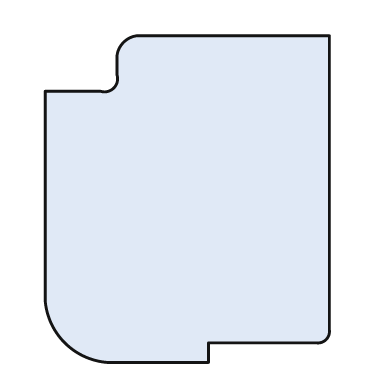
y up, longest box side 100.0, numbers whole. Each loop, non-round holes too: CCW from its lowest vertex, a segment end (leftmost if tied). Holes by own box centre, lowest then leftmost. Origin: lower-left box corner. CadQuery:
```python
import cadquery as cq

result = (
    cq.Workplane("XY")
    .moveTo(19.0, 0.0)
    .lineTo(50.0, 0.0)
    .lineTo(50.0, 6.0)
    .lineTo(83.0, 6.0)
    .threePointArc((86.0, 7.0), (87.0, 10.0))
    .lineTo(87.0, 100.0)
    .lineTo(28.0, 100.0)
    .threePointArc((24.0, 98.0), (22.0, 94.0))
    .lineTo(22.0, 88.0)
    .threePointArc((21.0, 84.0), (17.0, 83.0))
    .lineTo(0.0, 83.0)
    .lineTo(0.0, 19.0)
    .threePointArc((6.0, 6.0), (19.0, 0.0))
    .close()
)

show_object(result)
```